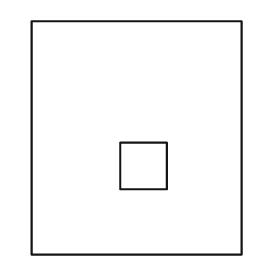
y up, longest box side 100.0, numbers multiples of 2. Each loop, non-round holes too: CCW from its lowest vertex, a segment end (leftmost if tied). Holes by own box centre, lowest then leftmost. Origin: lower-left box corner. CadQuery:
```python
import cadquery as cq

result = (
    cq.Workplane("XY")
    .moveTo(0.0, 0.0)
    .lineTo(90.0, 0.0)
    .lineTo(90.0, 100.0)
    .lineTo(0.0, 100.0)
    .close()
    .moveTo(38.0, 28.0)
    .lineTo(58.0, 28.0)
    .lineTo(58.0, 48.0)
    .lineTo(38.0, 48.0)
    .close()
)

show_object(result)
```